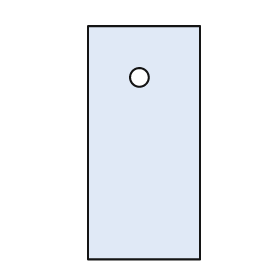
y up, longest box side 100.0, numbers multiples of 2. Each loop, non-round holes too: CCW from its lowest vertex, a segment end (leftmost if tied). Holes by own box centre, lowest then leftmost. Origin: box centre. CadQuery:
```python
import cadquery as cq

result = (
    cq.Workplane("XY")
    .moveTo(-24.0, -50.0)
    .lineTo(24.0, -50.0)
    .lineTo(24.0, 50.0)
    .lineTo(-24.0, 50.0)
    .close()
    .moveTo(-2.0, 28.0)
    .circle(4.0)
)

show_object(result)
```